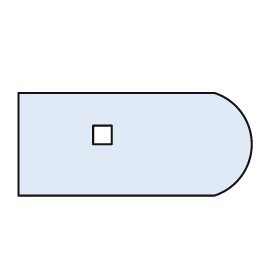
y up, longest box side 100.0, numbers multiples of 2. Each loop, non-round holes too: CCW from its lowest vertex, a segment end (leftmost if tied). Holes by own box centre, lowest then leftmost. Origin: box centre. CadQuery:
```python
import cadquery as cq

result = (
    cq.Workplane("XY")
    .moveTo(-50.0, -22.0)
    .lineTo(34.0, -22.0)
    .threePointArc((50.0, 0.0), (34.0, 22.0))
    .lineTo(-50.0, 22.0)
    .close()
    .moveTo(-18.0, 0.0)
    .lineTo(-10.0, 0.0)
    .lineTo(-10.0, 8.0)
    .lineTo(-18.0, 8.0)
    .close()
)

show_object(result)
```